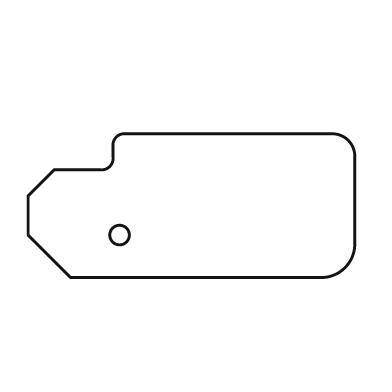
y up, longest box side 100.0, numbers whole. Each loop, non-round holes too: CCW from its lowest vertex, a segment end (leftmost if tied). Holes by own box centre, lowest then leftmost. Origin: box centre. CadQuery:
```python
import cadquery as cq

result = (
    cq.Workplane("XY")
    .moveTo(-37.0, -22.0)
    .lineTo(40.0, -22.0)
    .threePointArc((47.0, -19.0), (50.0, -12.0))
    .lineTo(50.0, 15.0)
    .threePointArc((48.0, 20.0), (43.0, 22.0))
    .lineTo(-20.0, 22.0)
    .threePointArc((-23.0, 21.0), (-24.0, 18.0))
    .lineTo(-24.0, 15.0)
    .threePointArc((-25.0, 12.0), (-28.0, 11.0))
    .lineTo(-42.0, 11.0)
    .lineTo(-50.0, 3.0)
    .lineTo(-50.0, -9.0)
    .close()
    .moveTo(-22.0, -9.0)
    .circle(3.0)
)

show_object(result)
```